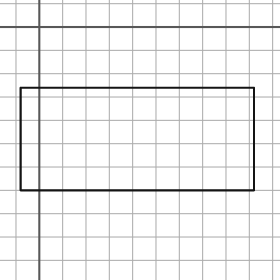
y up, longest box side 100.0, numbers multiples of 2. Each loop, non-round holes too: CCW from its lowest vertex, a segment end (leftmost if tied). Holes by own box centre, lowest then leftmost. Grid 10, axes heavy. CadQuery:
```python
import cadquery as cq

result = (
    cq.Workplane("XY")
    .moveTo(-8.0, -70.0)
    .lineTo(92.0, -70.0)
    .lineTo(92.0, -26.0)
    .lineTo(-8.0, -26.0)
    .close()
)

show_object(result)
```